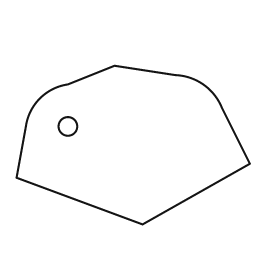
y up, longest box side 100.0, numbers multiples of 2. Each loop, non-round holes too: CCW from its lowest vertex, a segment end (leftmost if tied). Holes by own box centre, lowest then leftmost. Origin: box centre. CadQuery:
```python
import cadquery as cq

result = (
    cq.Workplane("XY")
    .moveTo(4.0, -34.0)
    .lineTo(50.0, -8.0)
    .lineTo(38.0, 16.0)
    .threePointArc((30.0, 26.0), (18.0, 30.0))
    .lineTo(-8.0, 34.0)
    .lineTo(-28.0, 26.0)
    .threePointArc((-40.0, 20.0), (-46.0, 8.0))
    .lineTo(-50.0, -14.0)
    .close()
    .moveTo(-28.0, 8.0)
    .circle(4.0)
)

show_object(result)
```